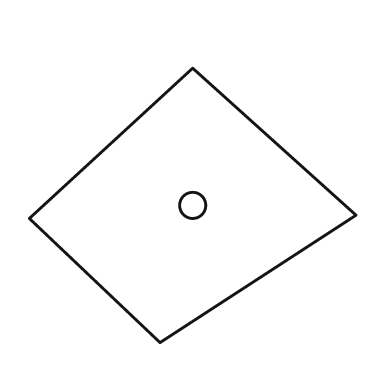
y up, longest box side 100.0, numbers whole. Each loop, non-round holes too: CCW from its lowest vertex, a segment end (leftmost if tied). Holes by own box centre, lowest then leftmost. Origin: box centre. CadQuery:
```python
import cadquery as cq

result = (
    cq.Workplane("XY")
    .moveTo(-10.0, -42.0)
    .lineTo(50.0, -3.0)
    .lineTo(0.0, 42.0)
    .lineTo(-50.0, -4.0)
    .close()
    .moveTo(0.0, 0.0)
    .circle(4.0)
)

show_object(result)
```